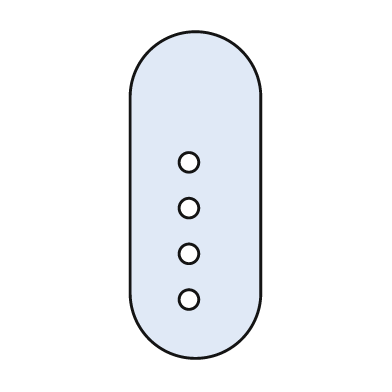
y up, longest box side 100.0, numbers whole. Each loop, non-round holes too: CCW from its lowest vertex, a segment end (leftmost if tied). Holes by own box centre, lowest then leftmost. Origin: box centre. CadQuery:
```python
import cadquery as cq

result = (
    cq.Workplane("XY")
    .moveTo(-20.0, -30.0)
    .threePointArc((0.0, -50.0), (20.0, -30.0))
    .lineTo(20.0, 30.0)
    .threePointArc((0.0, 50.0), (-20.0, 30.0))
    .close()
    .moveTo(-2.0, -32.0)
    .circle(3.0)
    .moveTo(-2.0, -18.0)
    .circle(3.0)
    .moveTo(-2.0, -4.0)
    .circle(3.0)
    .moveTo(-2.0, 10.0)
    .circle(3.0)
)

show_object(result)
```